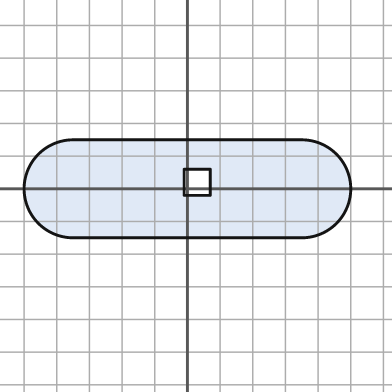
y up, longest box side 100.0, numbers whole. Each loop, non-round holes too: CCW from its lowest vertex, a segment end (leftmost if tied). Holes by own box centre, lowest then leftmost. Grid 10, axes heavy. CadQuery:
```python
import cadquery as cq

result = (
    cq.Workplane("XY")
    .moveTo(-35.0, -15.0)
    .lineTo(35.0, -15.0)
    .threePointArc((50.0, 0.0), (35.0, 15.0))
    .lineTo(-35.0, 15.0)
    .threePointArc((-50.0, 0.0), (-35.0, -15.0))
    .close()
    .moveTo(-1.0, -2.0)
    .lineTo(7.0, -2.0)
    .lineTo(7.0, 6.0)
    .lineTo(-1.0, 6.0)
    .close()
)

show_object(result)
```